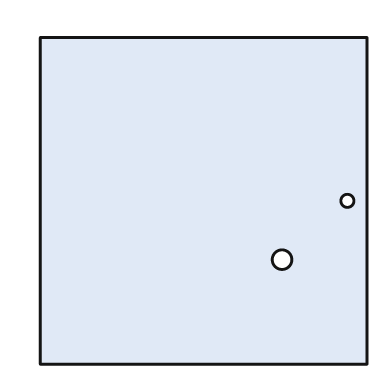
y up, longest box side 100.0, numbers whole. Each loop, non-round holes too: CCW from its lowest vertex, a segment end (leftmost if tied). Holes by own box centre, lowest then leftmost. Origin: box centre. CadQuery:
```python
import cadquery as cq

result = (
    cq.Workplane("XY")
    .moveTo(-50.0, -50.0)
    .lineTo(50.0, -50.0)
    .lineTo(50.0, 50.0)
    .lineTo(-50.0, 50.0)
    .close()
    .moveTo(24.0, -18.0)
    .circle(3.0)
    .moveTo(44.0, 0.0)
    .circle(2.0)
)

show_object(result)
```